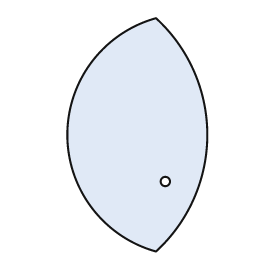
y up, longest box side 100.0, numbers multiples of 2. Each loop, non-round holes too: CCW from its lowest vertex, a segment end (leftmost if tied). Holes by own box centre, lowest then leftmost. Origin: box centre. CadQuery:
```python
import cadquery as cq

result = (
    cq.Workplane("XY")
    .moveTo(8.0, -50.0)
    .threePointArc((30.0, 0.0), (8.0, 50.0))
    .threePointArc((-30.0, 0.0), (8.0, -50.0))
    .close()
    .moveTo(12.0, -20.0)
    .circle(2.0)
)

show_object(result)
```